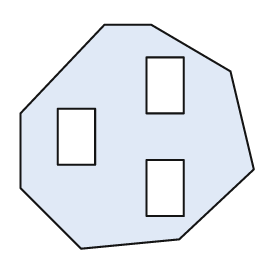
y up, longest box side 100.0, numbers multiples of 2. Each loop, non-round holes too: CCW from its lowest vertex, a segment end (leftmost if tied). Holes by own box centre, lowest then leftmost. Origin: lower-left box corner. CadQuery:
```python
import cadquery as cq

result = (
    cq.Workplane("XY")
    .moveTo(26.0, 0.0)
    .lineTo(68.0, 4.0)
    .lineTo(100.0, 34.0)
    .lineTo(90.0, 76.0)
    .lineTo(56.0, 96.0)
    .lineTo(36.0, 96.0)
    .lineTo(0.0, 58.0)
    .lineTo(0.0, 26.0)
    .close()
    .moveTo(54.0, 14.0)
    .lineTo(70.0, 14.0)
    .lineTo(70.0, 38.0)
    .lineTo(54.0, 38.0)
    .close()
    .moveTo(16.0, 36.0)
    .lineTo(32.0, 36.0)
    .lineTo(32.0, 60.0)
    .lineTo(16.0, 60.0)
    .close()
    .moveTo(54.0, 58.0)
    .lineTo(70.0, 58.0)
    .lineTo(70.0, 82.0)
    .lineTo(54.0, 82.0)
    .close()
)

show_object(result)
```